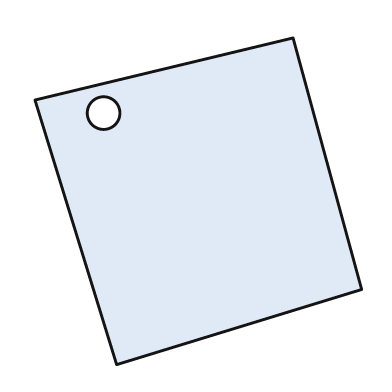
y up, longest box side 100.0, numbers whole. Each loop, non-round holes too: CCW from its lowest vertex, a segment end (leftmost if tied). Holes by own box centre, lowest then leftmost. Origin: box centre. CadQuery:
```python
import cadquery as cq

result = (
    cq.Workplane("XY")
    .moveTo(-25.0, -50.0)
    .lineTo(50.0, -27.0)
    .lineTo(29.0, 50.0)
    .lineTo(-50.0, 31.0)
    .close()
    .moveTo(-29.0, 27.0)
    .circle(5.0)
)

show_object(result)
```